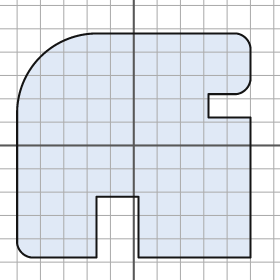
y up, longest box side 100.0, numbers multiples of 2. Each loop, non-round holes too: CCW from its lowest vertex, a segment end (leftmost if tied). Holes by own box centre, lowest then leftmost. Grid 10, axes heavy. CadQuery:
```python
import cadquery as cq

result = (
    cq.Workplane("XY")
    .moveTo(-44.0, -48.0)
    .lineTo(-16.0, -48.0)
    .lineTo(-16.0, -22.0)
    .lineTo(2.0, -22.0)
    .lineTo(2.0, -48.0)
    .lineTo(50.0, -48.0)
    .lineTo(50.0, 12.0)
    .lineTo(32.0, 12.0)
    .lineTo(32.0, 22.0)
    .lineTo(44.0, 22.0)
    .threePointArc((48.0, 24.0), (50.0, 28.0))
    .lineTo(50.0, 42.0)
    .threePointArc((48.0, 46.0), (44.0, 48.0))
    .lineTo(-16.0, 48.0)
    .threePointArc((-40.0, 38.0), (-50.0, 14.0))
    .lineTo(-50.0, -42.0)
    .threePointArc((-48.0, -46.0), (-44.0, -48.0))
    .close()
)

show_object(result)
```